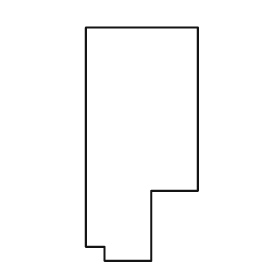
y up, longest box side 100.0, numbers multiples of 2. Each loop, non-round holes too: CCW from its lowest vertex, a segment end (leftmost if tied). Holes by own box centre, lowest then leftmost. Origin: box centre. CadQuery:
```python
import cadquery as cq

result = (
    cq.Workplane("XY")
    .moveTo(-16.0, -50.0)
    .lineTo(4.0, -50.0)
    .lineTo(4.0, -20.0)
    .lineTo(24.0, -20.0)
    .lineTo(24.0, 50.0)
    .lineTo(-24.0, 50.0)
    .lineTo(-24.0, -44.0)
    .lineTo(-16.0, -44.0)
    .close()
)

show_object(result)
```